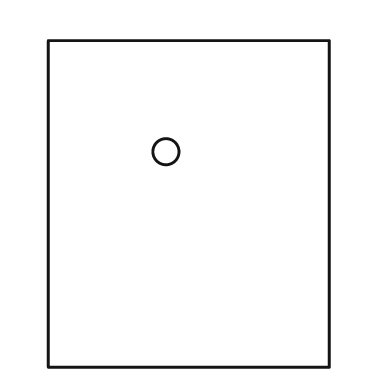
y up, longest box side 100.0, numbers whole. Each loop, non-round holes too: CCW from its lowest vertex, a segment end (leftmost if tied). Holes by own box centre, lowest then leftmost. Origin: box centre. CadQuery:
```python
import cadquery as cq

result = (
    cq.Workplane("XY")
    .moveTo(-43.0, -50.0)
    .lineTo(43.0, -50.0)
    .lineTo(43.0, 50.0)
    .lineTo(-43.0, 50.0)
    .close()
    .moveTo(-7.0, 16.0)
    .circle(4.0)
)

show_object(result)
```